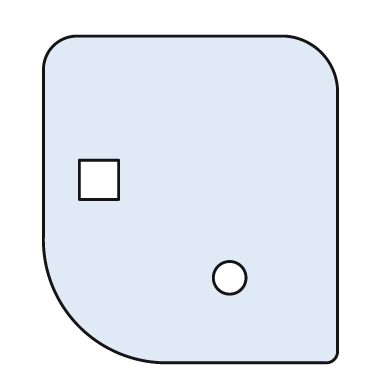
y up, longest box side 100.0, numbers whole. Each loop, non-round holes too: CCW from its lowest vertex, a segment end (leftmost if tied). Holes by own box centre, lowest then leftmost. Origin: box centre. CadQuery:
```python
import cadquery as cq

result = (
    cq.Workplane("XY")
    .moveTo(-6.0, -50.0)
    .lineTo(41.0, -50.0)
    .threePointArc((44.0, -49.0), (45.0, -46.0))
    .lineTo(45.0, 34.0)
    .threePointArc((40.0, 45.0), (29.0, 50.0))
    .lineTo(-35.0, 50.0)
    .threePointArc((-42.0, 47.0), (-45.0, 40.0))
    .lineTo(-45.0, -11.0)
    .threePointArc((-34.0, -39.0), (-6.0, -50.0))
    .close()
    .moveTo(12.0, -24.0)
    .circle(5.0)
    .moveTo(-34.0, 0.0)
    .lineTo(-22.0, 0.0)
    .lineTo(-22.0, 12.0)
    .lineTo(-34.0, 12.0)
    .close()
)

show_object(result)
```